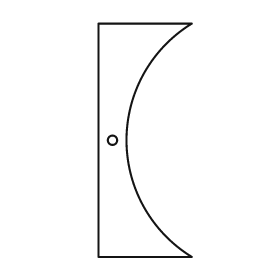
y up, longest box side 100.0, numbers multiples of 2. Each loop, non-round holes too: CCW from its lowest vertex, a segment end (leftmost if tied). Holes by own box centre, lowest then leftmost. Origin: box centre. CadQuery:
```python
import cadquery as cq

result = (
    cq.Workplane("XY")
    .moveTo(-20.0, -50.0)
    .lineTo(20.0, -50.0)
    .threePointArc((-8.0, 0.0), (20.0, 50.0))
    .lineTo(-20.0, 50.0)
    .close()
    .moveTo(-14.0, 0.0)
    .circle(2.0)
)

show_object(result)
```